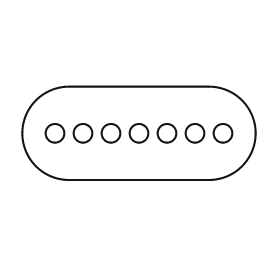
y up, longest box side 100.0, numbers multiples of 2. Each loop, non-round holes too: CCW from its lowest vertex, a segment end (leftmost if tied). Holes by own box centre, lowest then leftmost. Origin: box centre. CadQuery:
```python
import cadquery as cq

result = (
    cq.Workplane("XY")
    .moveTo(-30.0, -20.0)
    .lineTo(30.0, -20.0)
    .threePointArc((50.0, 0.0), (30.0, 20.0))
    .lineTo(-30.0, 20.0)
    .threePointArc((-50.0, 0.0), (-30.0, -20.0))
    .close()
    .moveTo(-36.0, 0.0)
    .circle(4.0)
    .moveTo(-24.0, 0.0)
    .circle(4.0)
    .moveTo(-12.0, 0.0)
    .circle(4.0)
    .moveTo(0.0, 0.0)
    .circle(4.0)
    .moveTo(12.0, 0.0)
    .circle(4.0)
    .moveTo(24.0, 0.0)
    .circle(4.0)
    .moveTo(36.0, 0.0)
    .circle(4.0)
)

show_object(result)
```